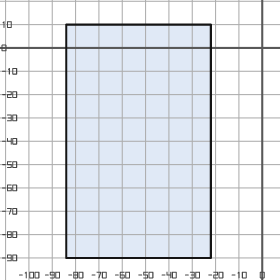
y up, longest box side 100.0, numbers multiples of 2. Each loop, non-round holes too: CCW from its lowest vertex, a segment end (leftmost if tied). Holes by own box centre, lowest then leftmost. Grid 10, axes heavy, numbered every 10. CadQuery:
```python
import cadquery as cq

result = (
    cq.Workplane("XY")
    .moveTo(-84.0, -90.0)
    .lineTo(-22.0, -90.0)
    .lineTo(-22.0, 10.0)
    .lineTo(-84.0, 10.0)
    .close()
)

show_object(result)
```